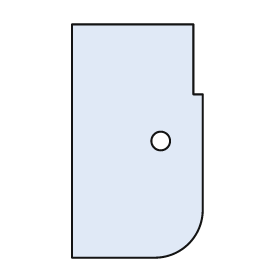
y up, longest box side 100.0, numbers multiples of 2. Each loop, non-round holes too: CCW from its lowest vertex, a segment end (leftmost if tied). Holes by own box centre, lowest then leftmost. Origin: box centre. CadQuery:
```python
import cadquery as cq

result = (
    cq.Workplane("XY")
    .moveTo(-28.0, -50.0)
    .lineTo(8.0, -50.0)
    .threePointArc((22.0, -44.0), (28.0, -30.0))
    .lineTo(28.0, 20.0)
    .lineTo(24.0, 20.0)
    .lineTo(24.0, 50.0)
    .lineTo(-28.0, 50.0)
    .close()
    .moveTo(10.0, 0.0)
    .circle(4.0)
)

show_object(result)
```